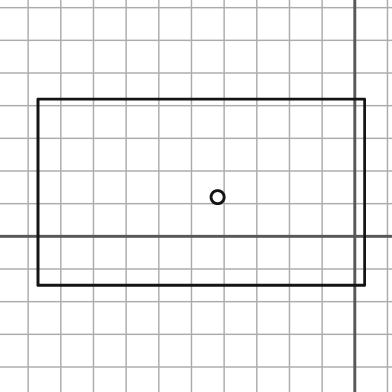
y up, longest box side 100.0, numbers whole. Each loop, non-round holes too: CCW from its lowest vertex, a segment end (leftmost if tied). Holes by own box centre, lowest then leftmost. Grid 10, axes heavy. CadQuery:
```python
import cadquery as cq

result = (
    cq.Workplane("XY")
    .moveTo(-97.0, -15.0)
    .lineTo(3.0, -15.0)
    .lineTo(3.0, 42.0)
    .lineTo(-97.0, 42.0)
    .close()
    .moveTo(-42.0, 12.0)
    .circle(2.0)
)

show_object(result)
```